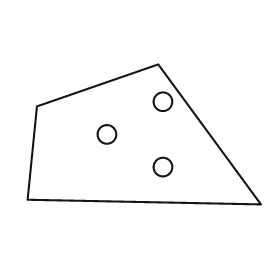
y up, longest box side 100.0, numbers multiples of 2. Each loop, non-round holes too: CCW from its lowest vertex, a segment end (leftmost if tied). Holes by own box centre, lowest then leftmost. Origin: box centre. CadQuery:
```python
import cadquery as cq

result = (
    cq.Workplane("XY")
    .moveTo(50.0, -30.0)
    .lineTo(6.0, 30.0)
    .lineTo(-46.0, 12.0)
    .lineTo(-50.0, -28.0)
    .close()
    .moveTo(8.0, -14.0)
    .circle(4.0)
    .moveTo(-16.0, 0.0)
    .circle(4.0)
    .moveTo(8.0, 14.0)
    .circle(4.0)
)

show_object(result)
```